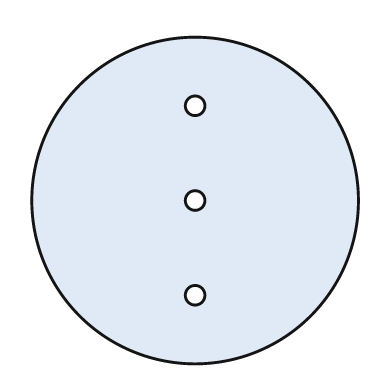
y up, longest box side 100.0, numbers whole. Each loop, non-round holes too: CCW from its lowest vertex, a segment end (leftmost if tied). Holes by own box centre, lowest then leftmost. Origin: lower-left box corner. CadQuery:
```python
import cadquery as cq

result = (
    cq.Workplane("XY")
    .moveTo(50.0, 50.0)
    .circle(50.0)
    .moveTo(50.0, 21.0)
    .circle(3.0)
    .moveTo(50.0, 50.0)
    .circle(3.0)
    .moveTo(50.0, 79.0)
    .circle(3.0)
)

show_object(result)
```